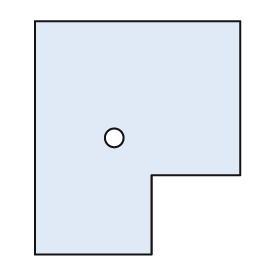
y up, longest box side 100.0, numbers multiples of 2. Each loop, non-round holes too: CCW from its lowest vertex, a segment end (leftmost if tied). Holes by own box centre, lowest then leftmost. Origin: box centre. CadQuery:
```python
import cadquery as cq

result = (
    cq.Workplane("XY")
    .moveTo(-44.0, -50.0)
    .lineTo(6.0, -50.0)
    .lineTo(6.0, -16.0)
    .lineTo(44.0, -16.0)
    .lineTo(44.0, 50.0)
    .lineTo(-44.0, 50.0)
    .close()
    .moveTo(-10.0, 0.0)
    .circle(4.0)
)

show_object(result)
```